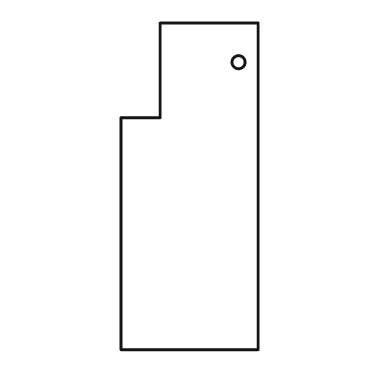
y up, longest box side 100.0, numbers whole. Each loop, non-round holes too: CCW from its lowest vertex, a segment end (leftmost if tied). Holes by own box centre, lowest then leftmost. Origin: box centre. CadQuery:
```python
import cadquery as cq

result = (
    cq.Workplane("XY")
    .moveTo(-21.0, -50.0)
    .lineTo(21.0, -50.0)
    .lineTo(21.0, 50.0)
    .lineTo(-9.0, 50.0)
    .lineTo(-9.0, 21.0)
    .lineTo(-21.0, 21.0)
    .close()
    .moveTo(15.0, 38.0)
    .circle(2.0)
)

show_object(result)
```